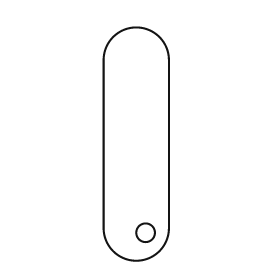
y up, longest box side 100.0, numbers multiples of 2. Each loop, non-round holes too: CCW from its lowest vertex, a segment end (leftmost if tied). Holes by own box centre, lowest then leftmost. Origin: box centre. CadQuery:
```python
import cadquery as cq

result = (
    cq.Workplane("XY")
    .moveTo(-14.0, -36.0)
    .threePointArc((0.0, -50.0), (14.0, -36.0))
    .lineTo(14.0, 36.0)
    .threePointArc((0.0, 50.0), (-14.0, 36.0))
    .close()
    .moveTo(4.0, -38.0)
    .circle(4.0)
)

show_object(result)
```